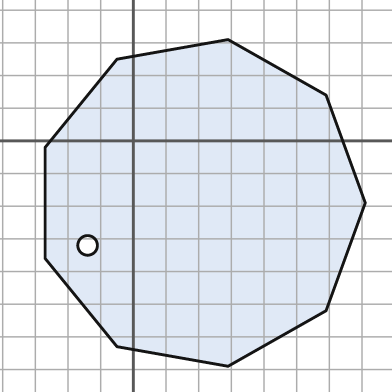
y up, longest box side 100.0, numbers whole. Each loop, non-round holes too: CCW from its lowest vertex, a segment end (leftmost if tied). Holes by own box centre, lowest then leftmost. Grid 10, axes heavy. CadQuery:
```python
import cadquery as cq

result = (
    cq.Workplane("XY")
    .moveTo(29.0, -69.0)
    .lineTo(59.0, -52.0)
    .lineTo(71.0, -19.0)
    .lineTo(59.0, 14.0)
    .lineTo(29.0, 31.0)
    .lineTo(-5.0, 25.0)
    .lineTo(-27.0, -2.0)
    .lineTo(-27.0, -36.0)
    .lineTo(-5.0, -63.0)
    .close()
    .moveTo(-14.0, -32.0)
    .circle(3.0)
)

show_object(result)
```